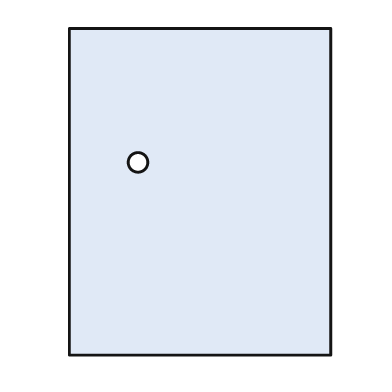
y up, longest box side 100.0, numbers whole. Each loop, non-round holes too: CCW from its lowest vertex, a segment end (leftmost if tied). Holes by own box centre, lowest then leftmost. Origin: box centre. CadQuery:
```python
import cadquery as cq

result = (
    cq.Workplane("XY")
    .moveTo(-40.0, -50.0)
    .lineTo(40.0, -50.0)
    .lineTo(40.0, 50.0)
    .lineTo(-40.0, 50.0)
    .close()
    .moveTo(-19.0, 9.0)
    .circle(3.0)
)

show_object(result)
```